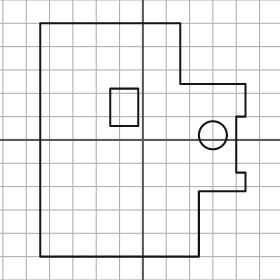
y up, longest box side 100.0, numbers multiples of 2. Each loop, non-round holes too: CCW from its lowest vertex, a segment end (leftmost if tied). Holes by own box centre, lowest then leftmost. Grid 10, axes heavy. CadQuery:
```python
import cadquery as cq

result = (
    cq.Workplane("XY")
    .moveTo(-44.0, -50.0)
    .lineTo(24.0, -50.0)
    .lineTo(24.0, -22.0)
    .lineTo(44.0, -22.0)
    .lineTo(44.0, -14.0)
    .lineTo(40.0, -14.0)
    .lineTo(40.0, 10.0)
    .lineTo(44.0, 10.0)
    .lineTo(44.0, 24.0)
    .lineTo(16.0, 24.0)
    .lineTo(16.0, 50.0)
    .lineTo(-44.0, 50.0)
    .close()
    .moveTo(30.0, 2.0)
    .circle(6.0)
    .moveTo(-14.0, 6.0)
    .lineTo(-2.0, 6.0)
    .lineTo(-2.0, 22.0)
    .lineTo(-14.0, 22.0)
    .close()
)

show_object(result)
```